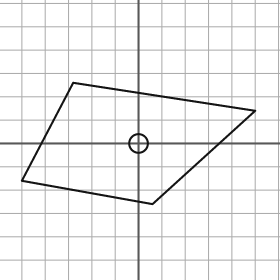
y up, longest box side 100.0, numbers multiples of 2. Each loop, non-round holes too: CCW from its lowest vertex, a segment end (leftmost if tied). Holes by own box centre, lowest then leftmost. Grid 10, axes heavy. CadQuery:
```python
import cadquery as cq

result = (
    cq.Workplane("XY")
    .moveTo(6.0, -26.0)
    .lineTo(50.0, 14.0)
    .lineTo(-28.0, 26.0)
    .lineTo(-50.0, -16.0)
    .close()
    .moveTo(0.0, 0.0)
    .circle(4.0)
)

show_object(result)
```